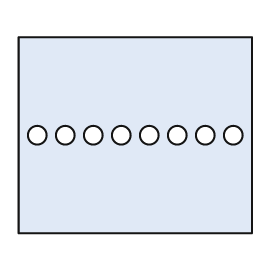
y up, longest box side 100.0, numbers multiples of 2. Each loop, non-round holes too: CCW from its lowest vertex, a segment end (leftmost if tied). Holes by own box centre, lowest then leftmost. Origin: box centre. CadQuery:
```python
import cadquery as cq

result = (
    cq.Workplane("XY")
    .moveTo(-50.0, -42.0)
    .lineTo(50.0, -42.0)
    .lineTo(50.0, 42.0)
    .lineTo(-50.0, 42.0)
    .close()
    .moveTo(-42.0, 0.0)
    .circle(4.0)
    .moveTo(-30.0, 0.0)
    .circle(4.0)
    .moveTo(-18.0, 0.0)
    .circle(4.0)
    .moveTo(-6.0, 0.0)
    .circle(4.0)
    .moveTo(6.0, 0.0)
    .circle(4.0)
    .moveTo(18.0, 0.0)
    .circle(4.0)
    .moveTo(30.0, 0.0)
    .circle(4.0)
    .moveTo(42.0, 0.0)
    .circle(4.0)
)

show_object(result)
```